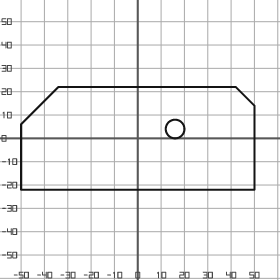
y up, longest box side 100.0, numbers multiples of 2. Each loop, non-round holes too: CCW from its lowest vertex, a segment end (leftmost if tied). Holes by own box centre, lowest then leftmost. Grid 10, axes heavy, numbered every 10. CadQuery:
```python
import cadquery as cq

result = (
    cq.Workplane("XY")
    .moveTo(-50.0, -22.0)
    .lineTo(50.0, -22.0)
    .lineTo(50.0, 14.0)
    .lineTo(42.0, 22.0)
    .lineTo(-34.0, 22.0)
    .lineTo(-50.0, 6.0)
    .close()
    .moveTo(16.0, 4.0)
    .circle(4.0)
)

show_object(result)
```